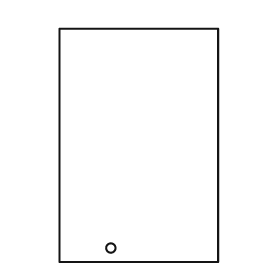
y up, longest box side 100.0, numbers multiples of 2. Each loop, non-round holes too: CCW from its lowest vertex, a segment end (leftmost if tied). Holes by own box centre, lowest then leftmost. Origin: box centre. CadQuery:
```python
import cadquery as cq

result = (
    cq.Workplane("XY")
    .moveTo(-34.0, -50.0)
    .lineTo(34.0, -50.0)
    .lineTo(34.0, 50.0)
    .lineTo(-34.0, 50.0)
    .close()
    .moveTo(-12.0, -44.0)
    .circle(2.0)
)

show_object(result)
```